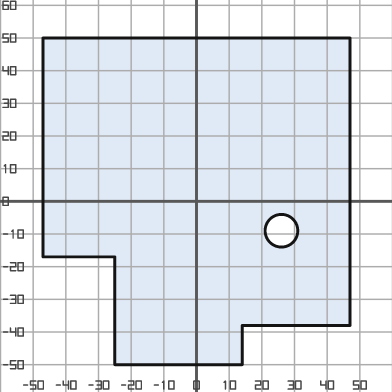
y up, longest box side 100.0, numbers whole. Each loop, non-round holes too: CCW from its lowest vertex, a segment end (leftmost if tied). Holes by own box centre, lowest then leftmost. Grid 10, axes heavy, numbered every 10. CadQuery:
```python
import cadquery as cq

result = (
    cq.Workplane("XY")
    .moveTo(-25.0, -50.0)
    .lineTo(14.0, -50.0)
    .lineTo(14.0, -38.0)
    .lineTo(47.0, -38.0)
    .lineTo(47.0, 50.0)
    .lineTo(-47.0, 50.0)
    .lineTo(-47.0, -17.0)
    .lineTo(-25.0, -17.0)
    .close()
    .moveTo(26.0, -9.0)
    .circle(5.0)
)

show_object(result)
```